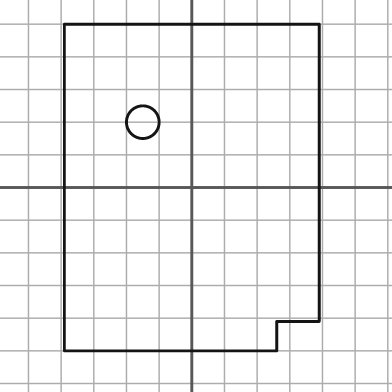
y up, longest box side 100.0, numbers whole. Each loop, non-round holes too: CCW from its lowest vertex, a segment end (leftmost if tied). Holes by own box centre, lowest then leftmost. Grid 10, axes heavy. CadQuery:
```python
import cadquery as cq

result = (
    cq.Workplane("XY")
    .moveTo(-39.0, -50.0)
    .lineTo(26.0, -50.0)
    .lineTo(26.0, -41.0)
    .lineTo(39.0, -41.0)
    .lineTo(39.0, 50.0)
    .lineTo(-39.0, 50.0)
    .close()
    .moveTo(-15.0, 20.0)
    .circle(5.0)
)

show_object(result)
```